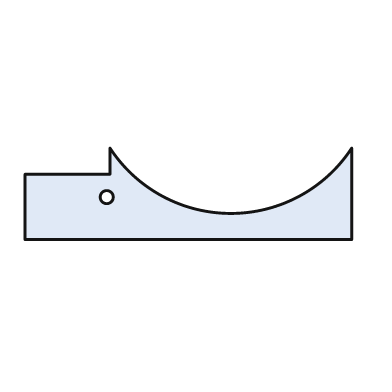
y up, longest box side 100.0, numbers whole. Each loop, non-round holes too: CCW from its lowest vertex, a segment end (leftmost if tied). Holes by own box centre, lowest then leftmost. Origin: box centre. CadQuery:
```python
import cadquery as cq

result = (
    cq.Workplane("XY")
    .moveTo(-50.0, -14.0)
    .lineTo(50.0, -14.0)
    .lineTo(50.0, 14.0)
    .threePointArc((13.0, -6.0), (-24.0, 14.0))
    .lineTo(-24.0, 6.0)
    .lineTo(-50.0, 6.0)
    .close()
    .moveTo(-25.0, -1.0)
    .circle(2.0)
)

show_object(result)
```